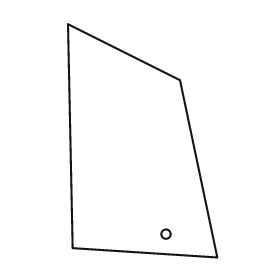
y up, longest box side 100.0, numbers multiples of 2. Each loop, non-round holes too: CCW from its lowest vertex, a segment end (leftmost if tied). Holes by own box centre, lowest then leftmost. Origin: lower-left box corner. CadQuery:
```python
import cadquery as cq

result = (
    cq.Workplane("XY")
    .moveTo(64.0, 0.0)
    .lineTo(48.0, 76.0)
    .lineTo(0.0, 100.0)
    .lineTo(2.0, 4.0)
    .close()
    .moveTo(42.0, 10.0)
    .circle(2.0)
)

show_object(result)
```